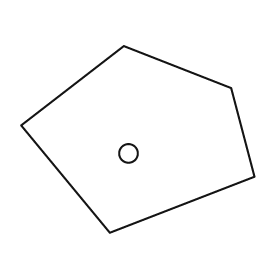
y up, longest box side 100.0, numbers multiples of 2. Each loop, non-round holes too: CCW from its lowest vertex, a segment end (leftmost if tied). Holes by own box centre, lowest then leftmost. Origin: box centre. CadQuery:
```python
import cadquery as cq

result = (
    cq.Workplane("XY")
    .moveTo(-12.0, -40.0)
    .lineTo(50.0, -16.0)
    .lineTo(40.0, 22.0)
    .lineTo(-6.0, 40.0)
    .lineTo(-50.0, 6.0)
    .close()
    .moveTo(-4.0, -6.0)
    .circle(4.0)
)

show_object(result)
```